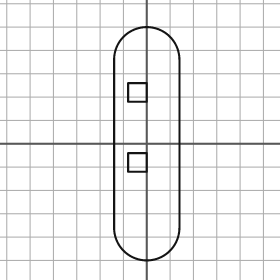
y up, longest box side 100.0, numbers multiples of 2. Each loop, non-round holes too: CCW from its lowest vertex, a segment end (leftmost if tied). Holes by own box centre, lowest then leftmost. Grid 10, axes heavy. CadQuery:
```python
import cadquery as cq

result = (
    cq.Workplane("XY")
    .moveTo(-14.0, -36.0)
    .threePointArc((0.0, -50.0), (14.0, -36.0))
    .lineTo(14.0, 36.0)
    .threePointArc((0.0, 50.0), (-14.0, 36.0))
    .close()
    .moveTo(-8.0, -12.0)
    .lineTo(0.0, -12.0)
    .lineTo(0.0, -4.0)
    .lineTo(-8.0, -4.0)
    .close()
    .moveTo(-8.0, 18.0)
    .lineTo(0.0, 18.0)
    .lineTo(0.0, 26.0)
    .lineTo(-8.0, 26.0)
    .close()
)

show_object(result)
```